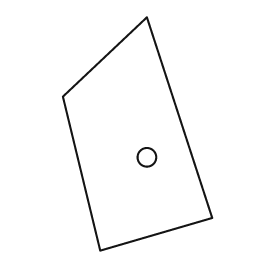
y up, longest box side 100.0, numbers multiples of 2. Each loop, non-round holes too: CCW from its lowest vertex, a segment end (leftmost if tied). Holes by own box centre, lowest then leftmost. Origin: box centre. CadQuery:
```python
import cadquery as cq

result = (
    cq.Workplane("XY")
    .moveTo(-16.0, -50.0)
    .lineTo(32.0, -36.0)
    .lineTo(4.0, 50.0)
    .lineTo(-32.0, 16.0)
    .close()
    .moveTo(4.0, -10.0)
    .circle(4.0)
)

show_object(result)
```